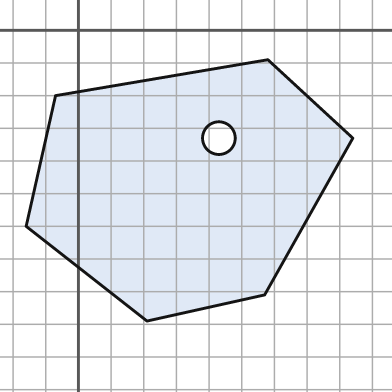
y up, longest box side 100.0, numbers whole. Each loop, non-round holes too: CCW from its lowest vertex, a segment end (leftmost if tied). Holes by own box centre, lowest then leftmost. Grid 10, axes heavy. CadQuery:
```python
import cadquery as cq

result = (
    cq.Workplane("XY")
    .moveTo(21.0, -89.0)
    .lineTo(57.0, -81.0)
    .lineTo(84.0, -33.0)
    .lineTo(58.0, -9.0)
    .lineTo(-7.0, -20.0)
    .lineTo(-16.0, -60.0)
    .close()
    .moveTo(43.0, -33.0)
    .circle(5.0)
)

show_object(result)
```